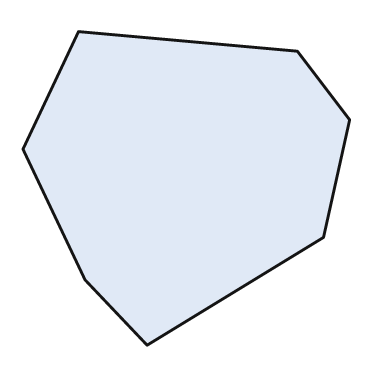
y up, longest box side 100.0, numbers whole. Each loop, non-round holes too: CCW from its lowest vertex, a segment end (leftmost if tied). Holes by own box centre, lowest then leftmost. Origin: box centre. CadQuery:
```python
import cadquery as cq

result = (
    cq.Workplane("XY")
    .moveTo(-12.0, -48.0)
    .lineTo(42.0, -15.0)
    .lineTo(50.0, 21.0)
    .lineTo(34.0, 42.0)
    .lineTo(-33.0, 48.0)
    .lineTo(-50.0, 12.0)
    .lineTo(-31.0, -28.0)
    .close()
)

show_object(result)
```